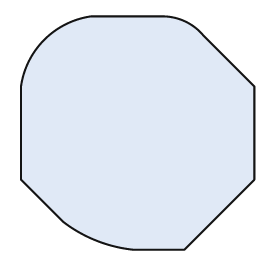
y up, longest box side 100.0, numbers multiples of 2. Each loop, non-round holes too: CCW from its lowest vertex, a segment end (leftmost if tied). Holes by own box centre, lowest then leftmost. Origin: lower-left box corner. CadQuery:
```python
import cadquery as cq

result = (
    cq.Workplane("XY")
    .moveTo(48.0, 0.0)
    .lineTo(70.0, 0.0)
    .lineTo(100.0, 30.0)
    .lineTo(100.0, 70.0)
    .lineTo(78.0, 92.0)
    .threePointArc((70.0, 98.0), (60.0, 100.0))
    .lineTo(30.0, 100.0)
    .threePointArc((10.0, 90.0), (0.0, 70.0))
    .lineTo(0.0, 30.0)
    .lineTo(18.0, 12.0)
    .threePointArc((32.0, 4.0), (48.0, 0.0))
    .close()
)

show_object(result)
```